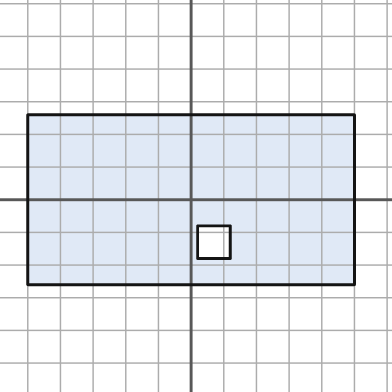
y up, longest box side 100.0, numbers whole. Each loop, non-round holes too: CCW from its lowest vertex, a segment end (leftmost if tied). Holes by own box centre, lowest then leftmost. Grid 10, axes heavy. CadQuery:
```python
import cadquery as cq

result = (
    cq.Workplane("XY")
    .moveTo(-50.0, -26.0)
    .lineTo(50.0, -26.0)
    .lineTo(50.0, 26.0)
    .lineTo(-50.0, 26.0)
    .close()
    .moveTo(2.0, -18.0)
    .lineTo(12.0, -18.0)
    .lineTo(12.0, -8.0)
    .lineTo(2.0, -8.0)
    .close()
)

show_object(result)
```